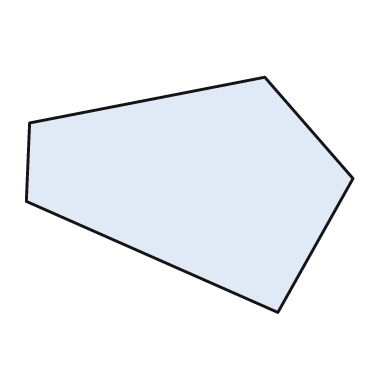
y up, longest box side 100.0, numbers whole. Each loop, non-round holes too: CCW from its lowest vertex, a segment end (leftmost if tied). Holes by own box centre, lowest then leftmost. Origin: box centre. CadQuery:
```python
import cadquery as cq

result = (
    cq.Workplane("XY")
    .moveTo(27.0, -36.0)
    .lineTo(50.0, 5.0)
    .lineTo(23.0, 36.0)
    .lineTo(-49.0, 22.0)
    .lineTo(-50.0, -2.0)
    .close()
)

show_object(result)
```